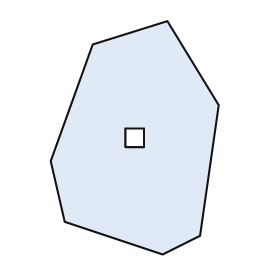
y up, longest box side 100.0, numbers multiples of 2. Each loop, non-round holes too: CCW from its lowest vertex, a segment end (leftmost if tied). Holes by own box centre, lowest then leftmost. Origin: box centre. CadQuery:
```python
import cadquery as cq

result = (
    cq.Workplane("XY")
    .moveTo(12.0, -50.0)
    .lineTo(28.0, -42.0)
    .lineTo(36.0, 14.0)
    .lineTo(14.0, 50.0)
    .lineTo(-18.0, 40.0)
    .lineTo(-36.0, -10.0)
    .lineTo(-30.0, -36.0)
    .close()
    .moveTo(-4.0, -4.0)
    .lineTo(4.0, -4.0)
    .lineTo(4.0, 4.0)
    .lineTo(-4.0, 4.0)
    .close()
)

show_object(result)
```